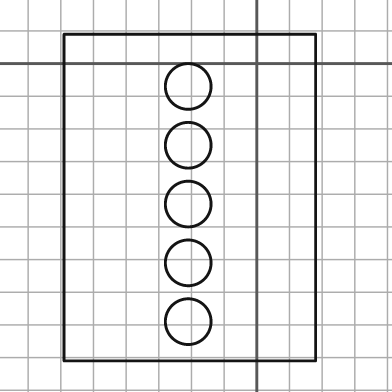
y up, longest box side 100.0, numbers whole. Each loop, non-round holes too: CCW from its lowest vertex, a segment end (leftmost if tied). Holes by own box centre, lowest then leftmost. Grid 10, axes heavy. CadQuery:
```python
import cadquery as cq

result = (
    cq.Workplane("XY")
    .moveTo(-59.0, -91.0)
    .lineTo(18.0, -91.0)
    .lineTo(18.0, 9.0)
    .lineTo(-59.0, 9.0)
    .close()
    .moveTo(-21.0, -79.0)
    .circle(7.0)
    .moveTo(-21.0, -61.0)
    .circle(7.0)
    .moveTo(-21.0, -43.0)
    .circle(7.0)
    .moveTo(-21.0, -25.0)
    .circle(7.0)
    .moveTo(-21.0, -7.0)
    .circle(7.0)
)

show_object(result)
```